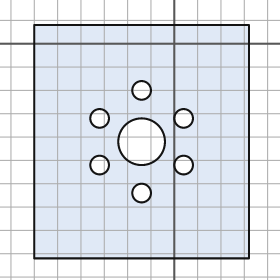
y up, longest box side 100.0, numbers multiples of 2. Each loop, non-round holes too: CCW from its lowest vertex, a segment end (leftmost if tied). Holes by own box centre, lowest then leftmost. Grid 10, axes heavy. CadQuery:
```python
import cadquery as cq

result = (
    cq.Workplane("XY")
    .moveTo(-60.0, -92.0)
    .lineTo(32.0, -92.0)
    .lineTo(32.0, 8.0)
    .lineTo(-60.0, 8.0)
    .close()
    .moveTo(-14.0, -64.0)
    .circle(4.0)
    .moveTo(-32.0, -52.0)
    .circle(4.0)
    .moveTo(4.0, -52.0)
    .circle(4.0)
    .moveTo(-14.0, -42.0)
    .circle(10.0)
    .moveTo(-32.0, -32.0)
    .circle(4.0)
    .moveTo(4.0, -32.0)
    .circle(4.0)
    .moveTo(-14.0, -20.0)
    .circle(4.0)
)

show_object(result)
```